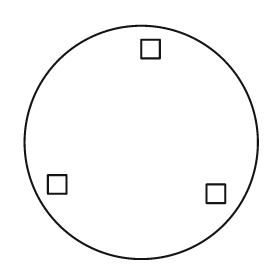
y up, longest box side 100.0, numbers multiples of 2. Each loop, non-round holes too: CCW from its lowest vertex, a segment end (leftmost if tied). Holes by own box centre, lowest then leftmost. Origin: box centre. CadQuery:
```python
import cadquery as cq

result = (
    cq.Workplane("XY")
    .moveTo(0.0, 0.0)
    .circle(50.0)
    .moveTo(28.0, -26.0)
    .lineTo(36.0, -26.0)
    .lineTo(36.0, -18.0)
    .lineTo(28.0, -18.0)
    .close()
    .moveTo(-40.0, -22.0)
    .lineTo(-32.0, -22.0)
    .lineTo(-32.0, -14.0)
    .lineTo(-40.0, -14.0)
    .close()
    .moveTo(0.0, 36.0)
    .lineTo(8.0, 36.0)
    .lineTo(8.0, 44.0)
    .lineTo(0.0, 44.0)
    .close()
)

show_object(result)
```